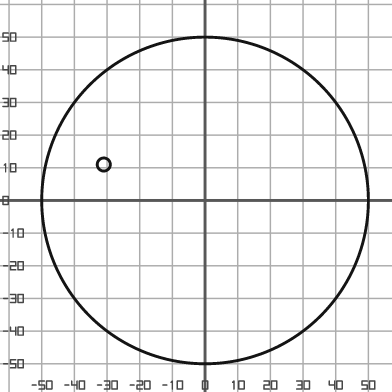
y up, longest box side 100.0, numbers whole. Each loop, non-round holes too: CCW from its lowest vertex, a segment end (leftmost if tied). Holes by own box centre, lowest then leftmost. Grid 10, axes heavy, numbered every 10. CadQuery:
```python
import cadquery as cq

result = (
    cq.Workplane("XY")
    .moveTo(0.0, 0.0)
    .circle(50.0)
    .moveTo(-31.0, 11.0)
    .circle(2.0)
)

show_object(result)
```